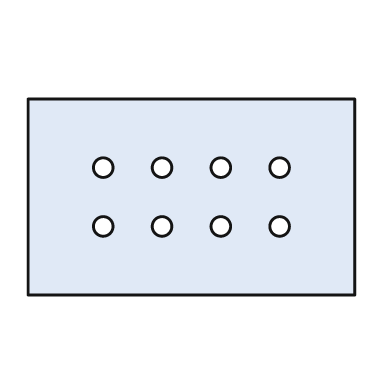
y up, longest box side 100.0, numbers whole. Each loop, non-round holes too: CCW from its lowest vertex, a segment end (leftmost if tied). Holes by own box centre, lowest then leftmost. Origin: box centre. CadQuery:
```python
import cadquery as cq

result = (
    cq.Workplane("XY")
    .moveTo(-50.0, -30.0)
    .lineTo(50.0, -30.0)
    .lineTo(50.0, 30.0)
    .lineTo(-50.0, 30.0)
    .close()
    .moveTo(-27.0, -9.0)
    .circle(3.0)
    .moveTo(-9.0, -9.0)
    .circle(3.0)
    .moveTo(9.0, -9.0)
    .circle(3.0)
    .moveTo(27.0, -9.0)
    .circle(3.0)
    .moveTo(-27.0, 9.0)
    .circle(3.0)
    .moveTo(-9.0, 9.0)
    .circle(3.0)
    .moveTo(9.0, 9.0)
    .circle(3.0)
    .moveTo(27.0, 9.0)
    .circle(3.0)
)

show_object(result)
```